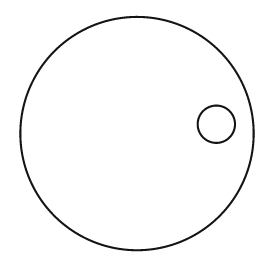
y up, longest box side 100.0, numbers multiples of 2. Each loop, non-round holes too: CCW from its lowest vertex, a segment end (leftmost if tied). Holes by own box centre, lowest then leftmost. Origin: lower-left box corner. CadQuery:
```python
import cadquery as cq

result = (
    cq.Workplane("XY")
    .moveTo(50.0, 50.0)
    .circle(50.0)
    .moveTo(84.0, 54.0)
    .circle(8.0)
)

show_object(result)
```